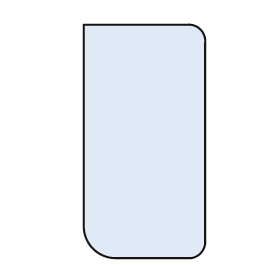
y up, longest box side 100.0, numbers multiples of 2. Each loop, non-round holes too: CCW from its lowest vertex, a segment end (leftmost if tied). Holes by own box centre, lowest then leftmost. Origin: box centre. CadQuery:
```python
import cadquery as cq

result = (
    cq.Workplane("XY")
    .moveTo(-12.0, -50.0)
    .lineTo(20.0, -50.0)
    .threePointArc((24.0, -48.0), (26.0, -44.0))
    .lineTo(26.0, 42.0)
    .threePointArc((24.0, 48.0), (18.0, 50.0))
    .lineTo(-26.0, 50.0)
    .lineTo(-26.0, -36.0)
    .threePointArc((-22.0, -46.0), (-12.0, -50.0))
    .close()
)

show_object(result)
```